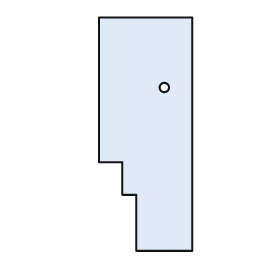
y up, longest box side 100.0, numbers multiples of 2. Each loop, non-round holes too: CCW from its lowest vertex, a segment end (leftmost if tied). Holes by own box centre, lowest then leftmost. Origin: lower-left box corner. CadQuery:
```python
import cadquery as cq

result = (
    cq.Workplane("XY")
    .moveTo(16.0, 0.0)
    .lineTo(40.0, 0.0)
    .lineTo(40.0, 100.0)
    .lineTo(0.0, 100.0)
    .lineTo(0.0, 38.0)
    .lineTo(10.0, 38.0)
    .lineTo(10.0, 24.0)
    .lineTo(16.0, 24.0)
    .close()
    .moveTo(28.0, 70.0)
    .circle(2.0)
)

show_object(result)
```